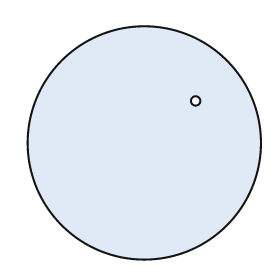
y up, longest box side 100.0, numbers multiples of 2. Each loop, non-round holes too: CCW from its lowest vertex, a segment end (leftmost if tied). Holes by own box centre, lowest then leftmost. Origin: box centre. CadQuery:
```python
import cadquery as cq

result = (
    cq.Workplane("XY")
    .moveTo(0.0, 0.0)
    .circle(50.0)
    .moveTo(22.0, 18.0)
    .circle(2.0)
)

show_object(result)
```